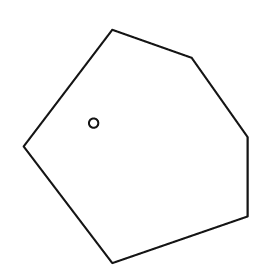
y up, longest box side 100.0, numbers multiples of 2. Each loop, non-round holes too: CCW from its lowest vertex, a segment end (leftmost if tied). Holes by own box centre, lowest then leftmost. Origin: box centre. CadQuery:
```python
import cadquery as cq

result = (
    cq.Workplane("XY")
    .moveTo(-10.0, -50.0)
    .lineTo(48.0, -30.0)
    .lineTo(48.0, 4.0)
    .lineTo(24.0, 38.0)
    .lineTo(-10.0, 50.0)
    .lineTo(-48.0, 0.0)
    .close()
    .moveTo(-18.0, 10.0)
    .circle(2.0)
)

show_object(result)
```